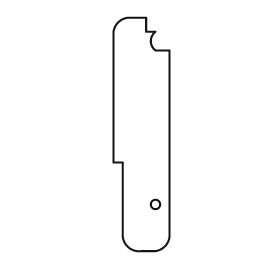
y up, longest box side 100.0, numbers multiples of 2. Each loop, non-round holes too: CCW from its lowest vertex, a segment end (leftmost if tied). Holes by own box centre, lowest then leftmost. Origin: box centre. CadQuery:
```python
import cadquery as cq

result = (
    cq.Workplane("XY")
    .moveTo(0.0, -50.0)
    .lineTo(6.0, -50.0)
    .threePointArc((10.0, -48.0), (12.0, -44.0))
    .lineTo(12.0, 36.0)
    .lineTo(6.0, 36.0)
    .threePointArc((4.0, 40.0), (6.0, 44.0))
    .lineTo(2.0, 44.0)
    .lineTo(2.0, 50.0)
    .lineTo(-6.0, 50.0)
    .threePointArc((-10.0, 48.0), (-12.0, 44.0))
    .lineTo(-12.0, -12.0)
    .lineTo(-8.0, -12.0)
    .lineTo(-8.0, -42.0)
    .threePointArc((-6.0, -48.0), (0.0, -50.0))
    .close()
    .moveTo(6.0, -30.0)
    .circle(2.0)
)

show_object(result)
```